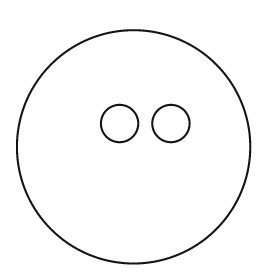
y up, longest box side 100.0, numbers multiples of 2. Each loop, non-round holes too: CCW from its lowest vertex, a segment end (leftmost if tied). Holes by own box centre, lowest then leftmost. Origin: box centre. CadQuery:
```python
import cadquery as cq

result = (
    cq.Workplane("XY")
    .moveTo(0.0, 0.0)
    .circle(50.0)
    .moveTo(-6.0, 10.0)
    .circle(8.0)
    .moveTo(16.0, 10.0)
    .circle(8.0)
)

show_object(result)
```